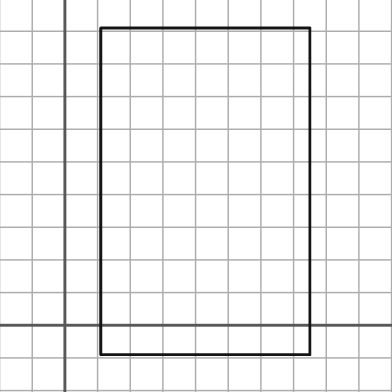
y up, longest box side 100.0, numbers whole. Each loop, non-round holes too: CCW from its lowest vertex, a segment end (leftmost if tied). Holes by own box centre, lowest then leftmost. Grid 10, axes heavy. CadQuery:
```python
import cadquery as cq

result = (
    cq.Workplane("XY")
    .moveTo(11.0, -9.0)
    .lineTo(75.0, -9.0)
    .lineTo(75.0, 91.0)
    .lineTo(11.0, 91.0)
    .close()
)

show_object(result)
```